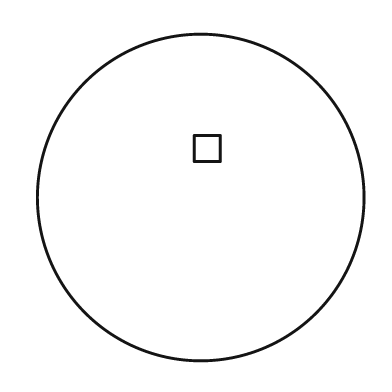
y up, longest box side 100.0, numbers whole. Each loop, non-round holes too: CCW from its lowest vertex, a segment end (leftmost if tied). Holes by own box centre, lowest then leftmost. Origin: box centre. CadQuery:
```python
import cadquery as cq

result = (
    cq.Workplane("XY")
    .moveTo(0.0, 0.0)
    .circle(50.0)
    .moveTo(-2.0, 11.0)
    .lineTo(6.0, 11.0)
    .lineTo(6.0, 19.0)
    .lineTo(-2.0, 19.0)
    .close()
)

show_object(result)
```